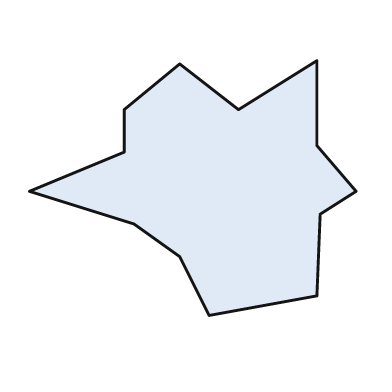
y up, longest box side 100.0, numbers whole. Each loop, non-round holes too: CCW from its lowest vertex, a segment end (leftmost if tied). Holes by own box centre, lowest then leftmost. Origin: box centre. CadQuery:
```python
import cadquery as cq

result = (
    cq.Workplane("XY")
    .moveTo(5.0, -39.0)
    .lineTo(38.0, -33.0)
    .lineTo(39.0, -8.0)
    .lineTo(50.0, -1.0)
    .lineTo(38.0, 13.0)
    .lineTo(38.0, 39.0)
    .lineTo(14.0, 24.0)
    .lineTo(-4.0, 38.0)
    .lineTo(-21.0, 24.0)
    .lineTo(-21.0, 11.0)
    .lineTo(-50.0, -1.0)
    .lineTo(-18.0, -11.0)
    .lineTo(-4.0, -21.0)
    .close()
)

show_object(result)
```